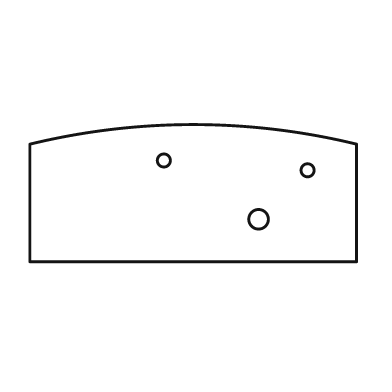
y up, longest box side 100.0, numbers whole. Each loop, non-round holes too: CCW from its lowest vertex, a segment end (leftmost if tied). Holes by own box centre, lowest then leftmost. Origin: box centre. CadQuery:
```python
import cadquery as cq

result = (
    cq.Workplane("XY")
    .moveTo(-50.0, -21.0)
    .lineTo(50.0, -21.0)
    .lineTo(50.0, 15.0)
    .threePointArc((0.0, 21.0), (-50.0, 15.0))
    .close()
    .moveTo(20.0, -8.0)
    .circle(3.0)
    .moveTo(35.0, 7.0)
    .circle(2.0)
    .moveTo(-9.0, 10.0)
    .circle(2.0)
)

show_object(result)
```